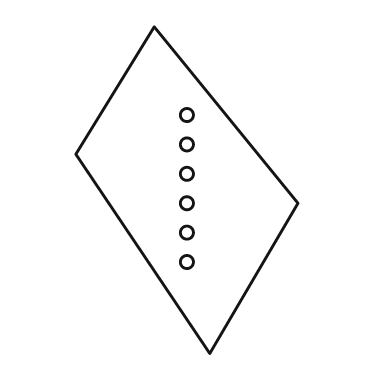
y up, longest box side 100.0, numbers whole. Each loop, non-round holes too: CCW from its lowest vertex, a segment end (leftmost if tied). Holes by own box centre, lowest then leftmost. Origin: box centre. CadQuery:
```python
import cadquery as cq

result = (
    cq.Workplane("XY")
    .moveTo(7.0, -50.0)
    .lineTo(34.0, -4.0)
    .lineTo(-10.0, 50.0)
    .lineTo(-34.0, 11.0)
    .close()
    .moveTo(0.0, -22.0)
    .circle(2.0)
    .moveTo(0.0, -13.0)
    .circle(2.0)
    .moveTo(0.0, -4.0)
    .circle(2.0)
    .moveTo(0.0, 5.0)
    .circle(2.0)
    .moveTo(0.0, 14.0)
    .circle(2.0)
    .moveTo(0.0, 23.0)
    .circle(2.0)
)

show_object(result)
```